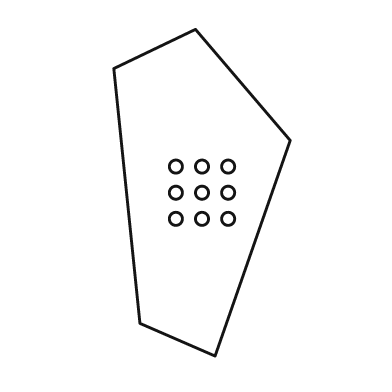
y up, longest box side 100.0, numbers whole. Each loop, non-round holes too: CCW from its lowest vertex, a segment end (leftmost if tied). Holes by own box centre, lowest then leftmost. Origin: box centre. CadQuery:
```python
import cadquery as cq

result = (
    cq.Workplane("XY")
    .moveTo(4.0, -50.0)
    .lineTo(27.0, 16.0)
    .lineTo(-2.0, 50.0)
    .lineTo(-27.0, 38.0)
    .lineTo(-19.0, -40.0)
    .close()
    .moveTo(-8.0, -8.0)
    .circle(2.0)
    .moveTo(0.0, -8.0)
    .circle(2.0)
    .moveTo(8.0, -8.0)
    .circle(2.0)
    .moveTo(-8.0, 0.0)
    .circle(2.0)
    .moveTo(0.0, 0.0)
    .circle(2.0)
    .moveTo(8.0, 0.0)
    .circle(2.0)
    .moveTo(-8.0, 8.0)
    .circle(2.0)
    .moveTo(0.0, 8.0)
    .circle(2.0)
    .moveTo(8.0, 8.0)
    .circle(2.0)
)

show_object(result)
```